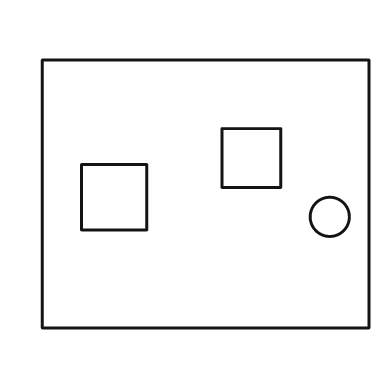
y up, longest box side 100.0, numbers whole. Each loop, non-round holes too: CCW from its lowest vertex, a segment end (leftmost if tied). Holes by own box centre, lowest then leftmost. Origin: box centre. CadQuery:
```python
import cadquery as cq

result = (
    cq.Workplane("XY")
    .moveTo(-50.0, -41.0)
    .lineTo(50.0, -41.0)
    .lineTo(50.0, 41.0)
    .lineTo(-50.0, 41.0)
    .close()
    .moveTo(38.0, -7.0)
    .circle(6.0)
    .moveTo(-38.0, -11.0)
    .lineTo(-18.0, -11.0)
    .lineTo(-18.0, 9.0)
    .lineTo(-38.0, 9.0)
    .close()
    .moveTo(5.0, 2.0)
    .lineTo(23.0, 2.0)
    .lineTo(23.0, 20.0)
    .lineTo(5.0, 20.0)
    .close()
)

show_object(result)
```